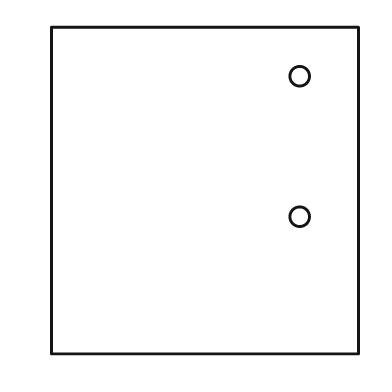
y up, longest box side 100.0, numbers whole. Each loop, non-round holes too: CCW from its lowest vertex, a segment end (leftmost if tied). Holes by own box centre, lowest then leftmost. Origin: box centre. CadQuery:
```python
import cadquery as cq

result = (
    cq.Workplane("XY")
    .moveTo(-47.0, -50.0)
    .lineTo(47.0, -50.0)
    .lineTo(47.0, 50.0)
    .lineTo(-47.0, 50.0)
    .close()
    .moveTo(29.0, -8.0)
    .circle(3.0)
    .moveTo(29.0, 35.0)
    .circle(3.0)
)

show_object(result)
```